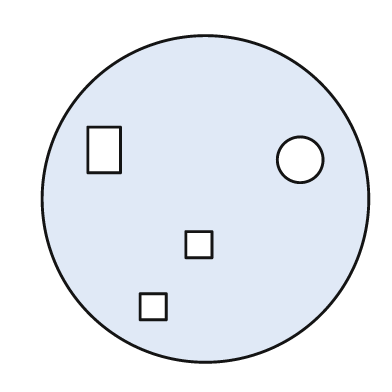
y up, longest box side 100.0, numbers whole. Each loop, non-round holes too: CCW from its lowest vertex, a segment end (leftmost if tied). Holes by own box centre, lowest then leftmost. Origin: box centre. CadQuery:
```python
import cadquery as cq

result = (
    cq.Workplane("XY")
    .moveTo(0.0, 0.0)
    .circle(50.0)
    .moveTo(-20.0, -37.0)
    .lineTo(-12.0, -37.0)
    .lineTo(-12.0, -29.0)
    .lineTo(-20.0, -29.0)
    .close()
    .moveTo(-6.0, -18.0)
    .lineTo(2.0, -18.0)
    .lineTo(2.0, -10.0)
    .lineTo(-6.0, -10.0)
    .close()
    .moveTo(29.0, 12.0)
    .circle(7.0)
    .moveTo(-36.0, 8.0)
    .lineTo(-26.0, 8.0)
    .lineTo(-26.0, 22.0)
    .lineTo(-36.0, 22.0)
    .close()
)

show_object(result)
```